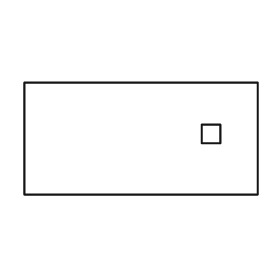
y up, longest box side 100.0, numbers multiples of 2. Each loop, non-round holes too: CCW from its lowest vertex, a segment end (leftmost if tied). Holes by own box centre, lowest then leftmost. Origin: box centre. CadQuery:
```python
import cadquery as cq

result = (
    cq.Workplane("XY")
    .moveTo(-50.0, -24.0)
    .lineTo(50.0, -24.0)
    .lineTo(50.0, 24.0)
    .lineTo(-50.0, 24.0)
    .close()
    .moveTo(26.0, -2.0)
    .lineTo(34.0, -2.0)
    .lineTo(34.0, 6.0)
    .lineTo(26.0, 6.0)
    .close()
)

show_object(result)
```